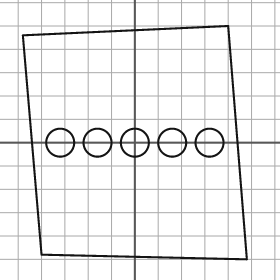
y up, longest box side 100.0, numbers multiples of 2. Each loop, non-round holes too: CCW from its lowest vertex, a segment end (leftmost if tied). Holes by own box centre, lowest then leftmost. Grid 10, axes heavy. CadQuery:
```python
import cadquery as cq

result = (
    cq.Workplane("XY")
    .moveTo(48.0, -50.0)
    .lineTo(40.0, 50.0)
    .lineTo(-48.0, 46.0)
    .lineTo(-40.0, -48.0)
    .close()
    .moveTo(-32.0, 0.0)
    .circle(6.0)
    .moveTo(-16.0, 0.0)
    .circle(6.0)
    .moveTo(0.0, 0.0)
    .circle(6.0)
    .moveTo(16.0, 0.0)
    .circle(6.0)
    .moveTo(32.0, 0.0)
    .circle(6.0)
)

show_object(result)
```